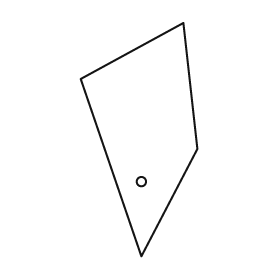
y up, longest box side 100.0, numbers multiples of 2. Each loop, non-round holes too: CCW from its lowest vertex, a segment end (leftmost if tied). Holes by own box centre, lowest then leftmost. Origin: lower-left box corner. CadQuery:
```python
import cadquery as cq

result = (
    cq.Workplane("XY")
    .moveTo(26.0, 0.0)
    .lineTo(50.0, 46.0)
    .lineTo(44.0, 100.0)
    .lineTo(0.0, 76.0)
    .close()
    .moveTo(26.0, 32.0)
    .circle(2.0)
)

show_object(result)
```